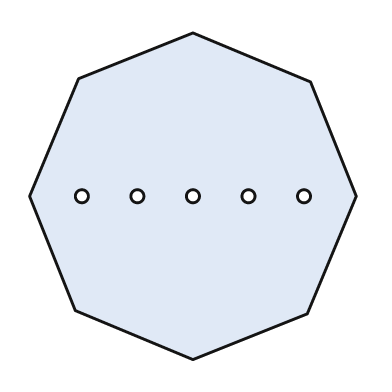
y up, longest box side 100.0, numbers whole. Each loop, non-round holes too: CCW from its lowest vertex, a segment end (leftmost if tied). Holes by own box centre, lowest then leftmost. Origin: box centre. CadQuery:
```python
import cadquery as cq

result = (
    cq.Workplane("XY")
    .moveTo(0.0, -50.0)
    .lineTo(35.0, -36.0)
    .lineTo(50.0, 0.0)
    .lineTo(36.0, 35.0)
    .lineTo(0.0, 50.0)
    .lineTo(-35.0, 36.0)
    .lineTo(-50.0, 0.0)
    .lineTo(-36.0, -35.0)
    .close()
    .moveTo(-34.0, 0.0)
    .circle(2.0)
    .moveTo(-17.0, 0.0)
    .circle(2.0)
    .moveTo(0.0, 0.0)
    .circle(2.0)
    .moveTo(17.0, 0.0)
    .circle(2.0)
    .moveTo(34.0, 0.0)
    .circle(2.0)
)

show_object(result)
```